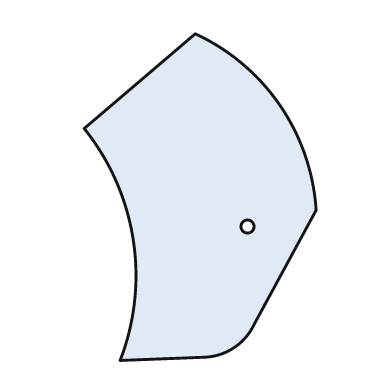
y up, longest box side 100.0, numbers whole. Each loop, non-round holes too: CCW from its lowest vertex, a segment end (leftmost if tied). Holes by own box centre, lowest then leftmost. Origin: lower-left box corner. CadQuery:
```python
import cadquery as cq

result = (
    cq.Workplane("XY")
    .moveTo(11.0, 0.0)
    .lineTo(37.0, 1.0)
    .threePointArc((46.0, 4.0), (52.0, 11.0))
    .lineTo(71.0, 46.0)
    .threePointArc((60.0, 78.0), (34.0, 100.0))
    .lineTo(0.0, 71.0)
    .threePointArc((15.0, 37.0), (11.0, 0.0))
    .close()
    .moveTo(50.0, 41.0)
    .circle(2.0)
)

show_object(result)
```